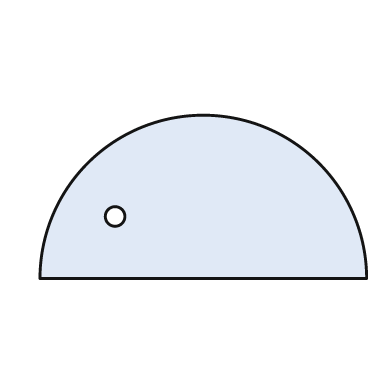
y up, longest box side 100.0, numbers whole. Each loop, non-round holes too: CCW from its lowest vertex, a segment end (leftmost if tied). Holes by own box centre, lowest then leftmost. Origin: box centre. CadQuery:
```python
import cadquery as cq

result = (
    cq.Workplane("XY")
    .moveTo(-50.0, -25.0)
    .lineTo(50.0, -25.0)
    .threePointArc((0.0, 25.0), (-50.0, -25.0))
    .close()
    .moveTo(-27.0, -6.0)
    .circle(3.0)
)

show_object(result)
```